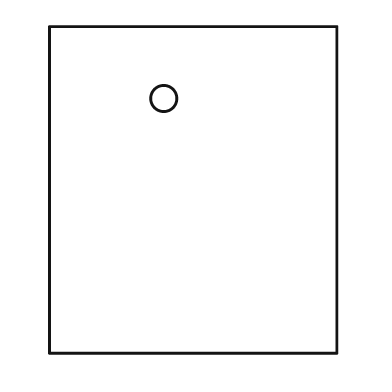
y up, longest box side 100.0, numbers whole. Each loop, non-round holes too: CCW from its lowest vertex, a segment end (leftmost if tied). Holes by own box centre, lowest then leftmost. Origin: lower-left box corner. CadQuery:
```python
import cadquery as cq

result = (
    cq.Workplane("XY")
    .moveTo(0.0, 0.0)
    .lineTo(88.0, 0.0)
    .lineTo(88.0, 100.0)
    .lineTo(0.0, 100.0)
    .close()
    .moveTo(35.0, 78.0)
    .circle(4.0)
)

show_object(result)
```